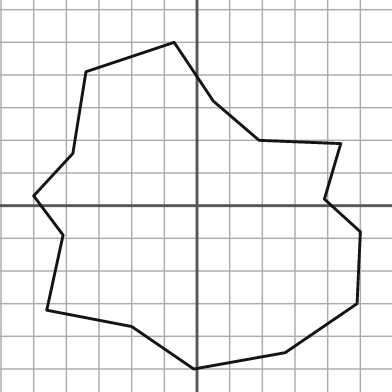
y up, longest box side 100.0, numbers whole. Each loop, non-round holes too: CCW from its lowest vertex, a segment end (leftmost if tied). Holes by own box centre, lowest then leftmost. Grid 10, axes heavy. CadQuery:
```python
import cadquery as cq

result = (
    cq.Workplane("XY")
    .moveTo(-1.0, -50.0)
    .lineTo(27.0, -45.0)
    .lineTo(49.0, -30.0)
    .lineTo(50.0, -8.0)
    .lineTo(39.0, 2.0)
    .lineTo(44.0, 19.0)
    .lineTo(19.0, 20.0)
    .lineTo(5.0, 32.0)
    .lineTo(-7.0, 50.0)
    .lineTo(-34.0, 41.0)
    .lineTo(-38.0, 16.0)
    .lineTo(-50.0, 3.0)
    .lineTo(-41.0, -9.0)
    .lineTo(-46.0, -32.0)
    .lineTo(-20.0, -37.0)
    .close()
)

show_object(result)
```